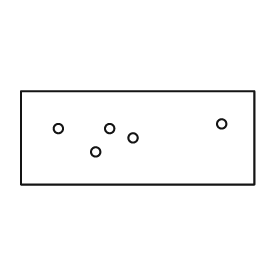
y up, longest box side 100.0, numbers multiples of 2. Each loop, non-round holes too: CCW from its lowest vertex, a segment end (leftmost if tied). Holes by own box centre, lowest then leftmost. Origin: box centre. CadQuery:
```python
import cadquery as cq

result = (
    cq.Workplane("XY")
    .moveTo(-50.0, -20.0)
    .lineTo(50.0, -20.0)
    .lineTo(50.0, 20.0)
    .lineTo(-50.0, 20.0)
    .close()
    .moveTo(-18.0, -6.0)
    .circle(2.0)
    .moveTo(-2.0, 0.0)
    .circle(2.0)
    .moveTo(-34.0, 4.0)
    .circle(2.0)
    .moveTo(-12.0, 4.0)
    .circle(2.0)
    .moveTo(36.0, 6.0)
    .circle(2.0)
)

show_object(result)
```